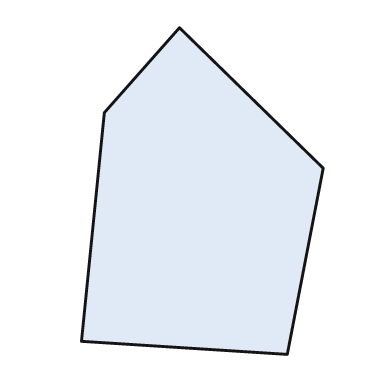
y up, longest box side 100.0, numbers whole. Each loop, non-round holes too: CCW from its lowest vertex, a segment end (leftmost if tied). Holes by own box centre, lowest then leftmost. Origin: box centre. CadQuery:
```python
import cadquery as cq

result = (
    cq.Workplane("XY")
    .moveTo(26.0, -50.0)
    .lineTo(37.0, 7.0)
    .lineTo(-7.0, 50.0)
    .lineTo(-30.0, 24.0)
    .lineTo(-37.0, -46.0)
    .close()
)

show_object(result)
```